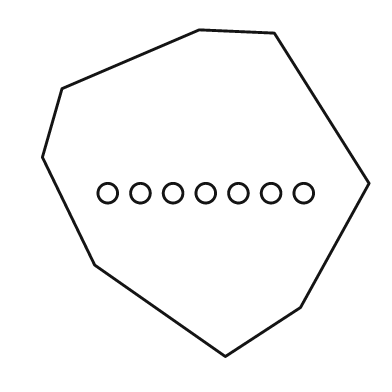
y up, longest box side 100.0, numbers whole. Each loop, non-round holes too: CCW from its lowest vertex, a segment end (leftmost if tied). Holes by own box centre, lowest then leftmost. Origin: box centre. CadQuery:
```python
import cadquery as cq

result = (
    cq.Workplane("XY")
    .moveTo(6.0, -50.0)
    .lineTo(29.0, -35.0)
    .lineTo(50.0, 3.0)
    .lineTo(21.0, 49.0)
    .lineTo(-2.0, 50.0)
    .lineTo(-44.0, 32.0)
    .lineTo(-50.0, 11.0)
    .lineTo(-34.0, -22.0)
    .close()
    .moveTo(-30.0, 0.0)
    .circle(3.0)
    .moveTo(-20.0, 0.0)
    .circle(3.0)
    .moveTo(-10.0, 0.0)
    .circle(3.0)
    .moveTo(0.0, 0.0)
    .circle(3.0)
    .moveTo(10.0, 0.0)
    .circle(3.0)
    .moveTo(20.0, 0.0)
    .circle(3.0)
    .moveTo(30.0, 0.0)
    .circle(3.0)
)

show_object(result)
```